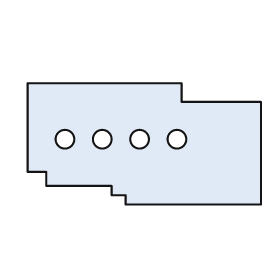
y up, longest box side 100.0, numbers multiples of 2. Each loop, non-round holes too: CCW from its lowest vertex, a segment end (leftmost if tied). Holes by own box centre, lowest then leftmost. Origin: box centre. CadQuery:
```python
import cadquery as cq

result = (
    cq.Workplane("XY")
    .moveTo(-8.0, -26.0)
    .lineTo(50.0, -26.0)
    .lineTo(50.0, 18.0)
    .lineTo(16.0, 18.0)
    .lineTo(16.0, 26.0)
    .lineTo(-50.0, 26.0)
    .lineTo(-50.0, -12.0)
    .lineTo(-42.0, -12.0)
    .lineTo(-42.0, -18.0)
    .lineTo(-14.0, -18.0)
    .lineTo(-14.0, -22.0)
    .lineTo(-8.0, -22.0)
    .close()
    .moveTo(-34.0, 2.0)
    .circle(4.0)
    .moveTo(-18.0, 2.0)
    .circle(4.0)
    .moveTo(-2.0, 2.0)
    .circle(4.0)
    .moveTo(14.0, 2.0)
    .circle(4.0)
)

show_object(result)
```